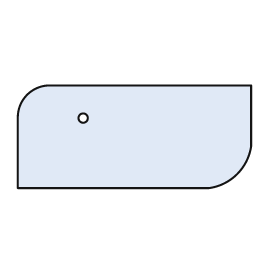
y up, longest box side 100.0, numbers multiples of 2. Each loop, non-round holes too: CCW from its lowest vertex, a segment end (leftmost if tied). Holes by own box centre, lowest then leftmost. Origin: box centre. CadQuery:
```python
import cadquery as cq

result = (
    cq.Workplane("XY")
    .moveTo(-50.0, -22.0)
    .lineTo(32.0, -22.0)
    .threePointArc((44.0, -16.0), (50.0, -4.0))
    .lineTo(50.0, 22.0)
    .lineTo(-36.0, 22.0)
    .threePointArc((-46.0, 18.0), (-50.0, 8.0))
    .close()
    .moveTo(-22.0, 8.0)
    .circle(2.0)
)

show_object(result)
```